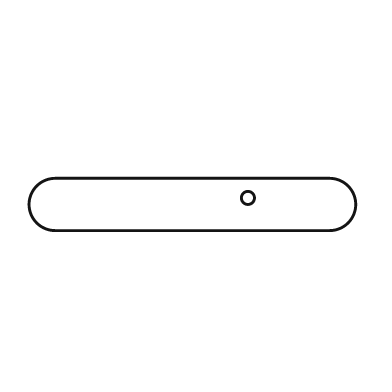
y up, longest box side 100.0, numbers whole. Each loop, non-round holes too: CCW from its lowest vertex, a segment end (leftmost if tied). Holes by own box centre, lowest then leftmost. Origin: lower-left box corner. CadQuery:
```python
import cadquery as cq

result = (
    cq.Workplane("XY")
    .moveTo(8.0, 0.0)
    .lineTo(92.0, 0.0)
    .threePointArc((100.0, 8.0), (92.0, 16.0))
    .lineTo(8.0, 16.0)
    .threePointArc((0.0, 8.0), (8.0, 0.0))
    .close()
    .moveTo(67.0, 10.0)
    .circle(2.0)
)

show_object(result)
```